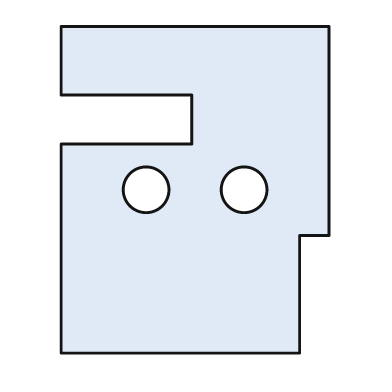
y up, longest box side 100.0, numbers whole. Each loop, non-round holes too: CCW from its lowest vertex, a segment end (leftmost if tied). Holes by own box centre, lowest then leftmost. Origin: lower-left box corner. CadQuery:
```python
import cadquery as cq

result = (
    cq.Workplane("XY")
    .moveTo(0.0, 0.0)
    .lineTo(73.0, 0.0)
    .lineTo(73.0, 36.0)
    .lineTo(82.0, 36.0)
    .lineTo(82.0, 100.0)
    .lineTo(0.0, 100.0)
    .lineTo(0.0, 79.0)
    .lineTo(40.0, 79.0)
    .lineTo(40.0, 64.0)
    .lineTo(0.0, 64.0)
    .close()
    .moveTo(26.0, 50.0)
    .circle(7.0)
    .moveTo(56.0, 50.0)
    .circle(7.0)
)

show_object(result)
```